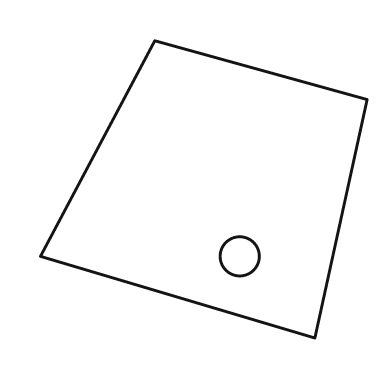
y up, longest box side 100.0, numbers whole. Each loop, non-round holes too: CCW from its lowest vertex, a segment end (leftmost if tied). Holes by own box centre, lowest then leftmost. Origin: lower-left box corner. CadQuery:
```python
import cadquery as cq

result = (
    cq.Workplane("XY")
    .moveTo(84.0, 0.0)
    .lineTo(100.0, 73.0)
    .lineTo(35.0, 91.0)
    .lineTo(0.0, 25.0)
    .close()
    .moveTo(61.0, 25.0)
    .circle(6.0)
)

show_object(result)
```